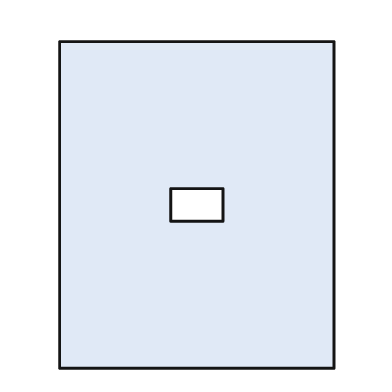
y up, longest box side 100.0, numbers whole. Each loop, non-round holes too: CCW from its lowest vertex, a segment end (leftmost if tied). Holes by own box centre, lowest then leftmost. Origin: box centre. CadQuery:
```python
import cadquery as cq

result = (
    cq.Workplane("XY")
    .moveTo(-42.0, -50.0)
    .lineTo(42.0, -50.0)
    .lineTo(42.0, 50.0)
    .lineTo(-42.0, 50.0)
    .close()
    .moveTo(-8.0, -5.0)
    .lineTo(8.0, -5.0)
    .lineTo(8.0, 5.0)
    .lineTo(-8.0, 5.0)
    .close()
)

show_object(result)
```